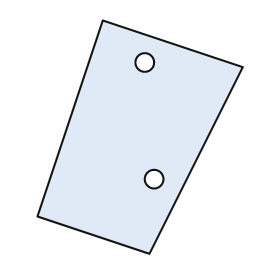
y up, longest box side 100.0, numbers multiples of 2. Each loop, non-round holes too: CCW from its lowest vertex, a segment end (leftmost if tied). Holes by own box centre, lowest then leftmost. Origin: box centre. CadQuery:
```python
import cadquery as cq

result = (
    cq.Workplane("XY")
    .moveTo(4.0, -50.0)
    .lineTo(44.0, 30.0)
    .lineTo(-16.0, 50.0)
    .lineTo(-44.0, -34.0)
    .close()
    .moveTo(6.0, -18.0)
    .circle(4.0)
    .moveTo(2.0, 32.0)
    .circle(4.0)
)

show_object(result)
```